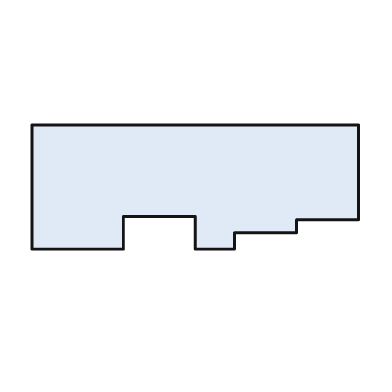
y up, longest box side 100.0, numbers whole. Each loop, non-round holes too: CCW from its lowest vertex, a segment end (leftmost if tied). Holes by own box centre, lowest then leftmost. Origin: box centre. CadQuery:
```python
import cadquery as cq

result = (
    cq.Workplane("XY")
    .moveTo(-50.0, -19.0)
    .lineTo(-22.0, -19.0)
    .lineTo(-22.0, -9.0)
    .lineTo(0.0, -9.0)
    .lineTo(0.0, -19.0)
    .lineTo(12.0, -19.0)
    .lineTo(12.0, -14.0)
    .lineTo(31.0, -14.0)
    .lineTo(31.0, -10.0)
    .lineTo(50.0, -10.0)
    .lineTo(50.0, 19.0)
    .lineTo(-50.0, 19.0)
    .close()
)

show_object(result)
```